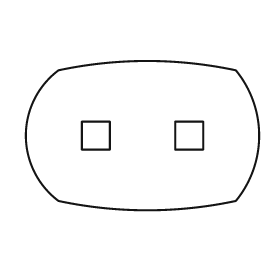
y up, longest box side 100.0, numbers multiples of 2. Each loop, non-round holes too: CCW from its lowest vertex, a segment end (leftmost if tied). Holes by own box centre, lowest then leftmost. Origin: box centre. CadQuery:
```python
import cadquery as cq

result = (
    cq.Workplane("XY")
    .moveTo(-36.0, -28.0)
    .threePointArc((2.0, -32.0), (40.0, -28.0))
    .threePointArc((50.0, 0.0), (40.0, 28.0))
    .threePointArc((2.0, 32.0), (-36.0, 28.0))
    .threePointArc((-50.0, 0.0), (-36.0, -28.0))
    .close()
    .moveTo(-26.0, -6.0)
    .lineTo(-14.0, -6.0)
    .lineTo(-14.0, 6.0)
    .lineTo(-26.0, 6.0)
    .close()
    .moveTo(14.0, -6.0)
    .lineTo(26.0, -6.0)
    .lineTo(26.0, 6.0)
    .lineTo(14.0, 6.0)
    .close()
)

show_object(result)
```